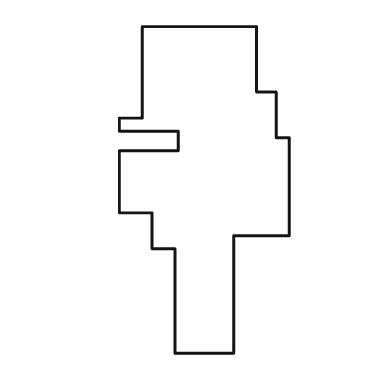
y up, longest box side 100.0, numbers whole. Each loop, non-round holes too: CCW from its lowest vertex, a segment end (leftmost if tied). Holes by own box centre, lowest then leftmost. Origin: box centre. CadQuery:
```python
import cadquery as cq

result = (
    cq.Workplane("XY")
    .moveTo(-9.0, -50.0)
    .lineTo(9.0, -50.0)
    .lineTo(9.0, -14.0)
    .lineTo(26.0, -14.0)
    .lineTo(26.0, 16.0)
    .lineTo(22.0, 16.0)
    .lineTo(22.0, 30.0)
    .lineTo(16.0, 30.0)
    .lineTo(16.0, 50.0)
    .lineTo(-19.0, 50.0)
    .lineTo(-19.0, 22.0)
    .lineTo(-26.0, 22.0)
    .lineTo(-26.0, 18.0)
    .lineTo(-8.0, 18.0)
    .lineTo(-8.0, 12.0)
    .lineTo(-26.0, 12.0)
    .lineTo(-26.0, -7.0)
    .lineTo(-16.0, -7.0)
    .lineTo(-16.0, -18.0)
    .lineTo(-9.0, -18.0)
    .close()
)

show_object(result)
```